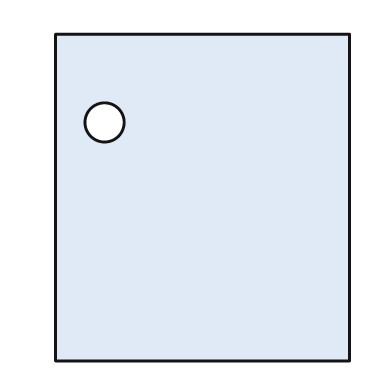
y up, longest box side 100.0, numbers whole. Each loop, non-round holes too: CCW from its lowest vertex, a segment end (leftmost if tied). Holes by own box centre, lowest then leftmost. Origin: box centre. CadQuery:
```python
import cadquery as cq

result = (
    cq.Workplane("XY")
    .moveTo(-45.0, -50.0)
    .lineTo(45.0, -50.0)
    .lineTo(45.0, 50.0)
    .lineTo(-45.0, 50.0)
    .close()
    .moveTo(-30.0, 23.0)
    .circle(6.0)
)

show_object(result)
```